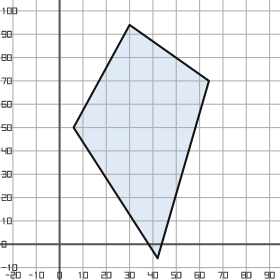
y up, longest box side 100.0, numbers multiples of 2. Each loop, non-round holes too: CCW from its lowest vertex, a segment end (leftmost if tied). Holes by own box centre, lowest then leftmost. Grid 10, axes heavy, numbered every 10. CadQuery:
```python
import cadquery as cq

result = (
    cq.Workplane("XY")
    .moveTo(42.0, -6.0)
    .lineTo(64.0, 70.0)
    .lineTo(30.0, 94.0)
    .lineTo(6.0, 50.0)
    .close()
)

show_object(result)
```